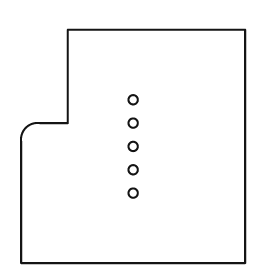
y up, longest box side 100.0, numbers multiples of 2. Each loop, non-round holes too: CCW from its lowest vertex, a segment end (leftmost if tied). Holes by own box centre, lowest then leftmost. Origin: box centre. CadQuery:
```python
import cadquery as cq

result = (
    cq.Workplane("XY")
    .moveTo(-48.0, -50.0)
    .lineTo(48.0, -50.0)
    .lineTo(48.0, 50.0)
    .lineTo(-28.0, 50.0)
    .lineTo(-28.0, 10.0)
    .lineTo(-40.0, 10.0)
    .threePointArc((-46.0, 8.0), (-48.0, 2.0))
    .close()
    .moveTo(0.0, -20.0)
    .circle(2.0)
    .moveTo(0.0, -10.0)
    .circle(2.0)
    .moveTo(0.0, 0.0)
    .circle(2.0)
    .moveTo(0.0, 10.0)
    .circle(2.0)
    .moveTo(0.0, 20.0)
    .circle(2.0)
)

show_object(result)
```